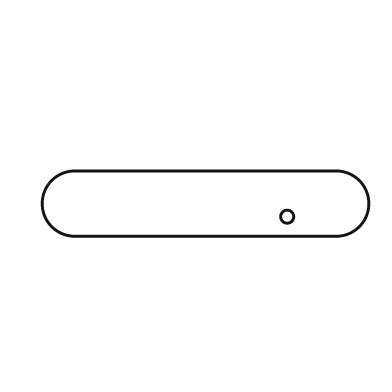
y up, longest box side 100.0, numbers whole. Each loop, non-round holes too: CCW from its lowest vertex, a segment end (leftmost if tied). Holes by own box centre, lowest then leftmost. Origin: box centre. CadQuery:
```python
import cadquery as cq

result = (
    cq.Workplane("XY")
    .moveTo(-40.0, -10.0)
    .lineTo(40.0, -10.0)
    .threePointArc((50.0, 0.0), (40.0, 10.0))
    .lineTo(-40.0, 10.0)
    .threePointArc((-50.0, 0.0), (-40.0, -10.0))
    .close()
    .moveTo(25.0, -4.0)
    .circle(2.0)
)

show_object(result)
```